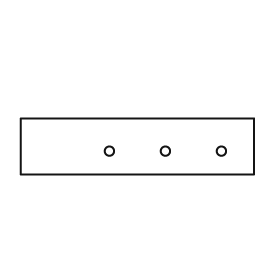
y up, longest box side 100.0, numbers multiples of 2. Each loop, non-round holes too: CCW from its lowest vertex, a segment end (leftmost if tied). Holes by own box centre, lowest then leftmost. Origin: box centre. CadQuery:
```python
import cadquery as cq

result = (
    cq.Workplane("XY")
    .moveTo(-50.0, -12.0)
    .lineTo(50.0, -12.0)
    .lineTo(50.0, 12.0)
    .lineTo(-50.0, 12.0)
    .close()
    .moveTo(-12.0, -2.0)
    .circle(2.0)
    .moveTo(12.0, -2.0)
    .circle(2.0)
    .moveTo(36.0, -2.0)
    .circle(2.0)
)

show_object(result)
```